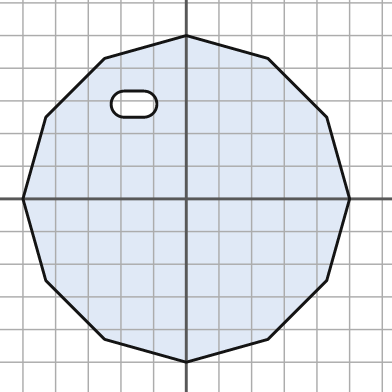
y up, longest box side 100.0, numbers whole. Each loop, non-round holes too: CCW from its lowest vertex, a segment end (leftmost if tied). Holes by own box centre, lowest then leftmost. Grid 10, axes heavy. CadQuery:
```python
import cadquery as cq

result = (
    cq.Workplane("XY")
    .moveTo(0.0, -50.0)
    .lineTo(25.0, -43.0)
    .lineTo(43.0, -25.0)
    .lineTo(50.0, 0.0)
    .lineTo(43.0, 25.0)
    .lineTo(25.0, 43.0)
    .lineTo(0.0, 50.0)
    .lineTo(-25.0, 43.0)
    .lineTo(-43.0, 25.0)
    .lineTo(-50.0, 0.0)
    .lineTo(-43.0, -25.0)
    .lineTo(-25.0, -43.0)
    .close()
    .moveTo(-19.0, 25.0)
    .lineTo(-13.0, 25.0)
    .threePointArc((-9.0, 29.0), (-13.0, 33.0))
    .lineTo(-19.0, 33.0)
    .threePointArc((-23.0, 29.0), (-19.0, 25.0))
    .close()
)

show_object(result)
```